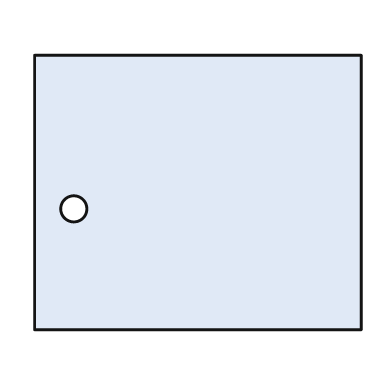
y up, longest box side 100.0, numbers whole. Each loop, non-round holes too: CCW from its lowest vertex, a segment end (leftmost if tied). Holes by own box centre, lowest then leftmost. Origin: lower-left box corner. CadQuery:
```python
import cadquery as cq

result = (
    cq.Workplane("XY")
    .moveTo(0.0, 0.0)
    .lineTo(100.0, 0.0)
    .lineTo(100.0, 84.0)
    .lineTo(0.0, 84.0)
    .close()
    .moveTo(12.0, 37.0)
    .circle(4.0)
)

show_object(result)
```